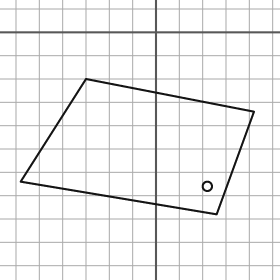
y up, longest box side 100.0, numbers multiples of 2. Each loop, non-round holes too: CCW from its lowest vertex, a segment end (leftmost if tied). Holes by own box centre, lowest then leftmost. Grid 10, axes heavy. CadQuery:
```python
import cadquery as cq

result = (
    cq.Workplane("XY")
    .moveTo(26.0, -78.0)
    .lineTo(42.0, -34.0)
    .lineTo(-30.0, -20.0)
    .lineTo(-58.0, -64.0)
    .close()
    .moveTo(22.0, -66.0)
    .circle(2.0)
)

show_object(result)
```